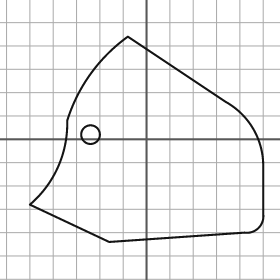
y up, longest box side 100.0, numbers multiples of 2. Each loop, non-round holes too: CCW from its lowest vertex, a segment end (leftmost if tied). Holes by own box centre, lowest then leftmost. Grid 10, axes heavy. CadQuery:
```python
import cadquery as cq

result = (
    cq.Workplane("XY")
    .moveTo(-16.0, -44.0)
    .lineTo(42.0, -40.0)
    .threePointArc((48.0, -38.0), (50.0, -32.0))
    .lineTo(50.0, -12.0)
    .threePointArc((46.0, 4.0), (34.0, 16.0))
    .lineTo(-8.0, 44.0)
    .threePointArc((-24.0, 28.0), (-34.0, 8.0))
    .threePointArc((-38.0, -12.0), (-50.0, -28.0))
    .close()
    .moveTo(-24.0, 2.0)
    .circle(4.0)
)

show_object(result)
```